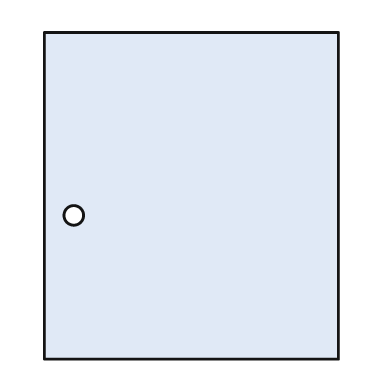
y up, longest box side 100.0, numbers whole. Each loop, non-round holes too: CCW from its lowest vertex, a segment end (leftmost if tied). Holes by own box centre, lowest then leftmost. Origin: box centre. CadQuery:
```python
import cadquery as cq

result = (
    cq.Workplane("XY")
    .moveTo(-45.0, -50.0)
    .lineTo(45.0, -50.0)
    .lineTo(45.0, 50.0)
    .lineTo(-45.0, 50.0)
    .close()
    .moveTo(-36.0, -6.0)
    .circle(3.0)
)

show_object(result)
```